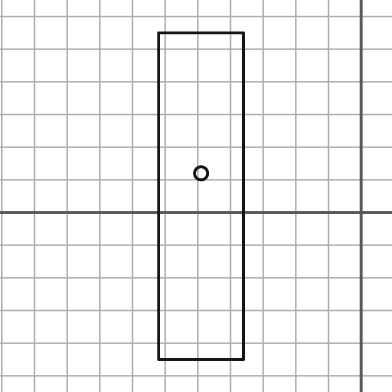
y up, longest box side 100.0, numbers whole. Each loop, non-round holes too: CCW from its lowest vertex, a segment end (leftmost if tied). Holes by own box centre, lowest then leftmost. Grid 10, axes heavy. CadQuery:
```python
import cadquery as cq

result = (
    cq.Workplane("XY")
    .moveTo(-62.0, -45.0)
    .lineTo(-36.0, -45.0)
    .lineTo(-36.0, 55.0)
    .lineTo(-62.0, 55.0)
    .close()
    .moveTo(-49.0, 12.0)
    .circle(2.0)
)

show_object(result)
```